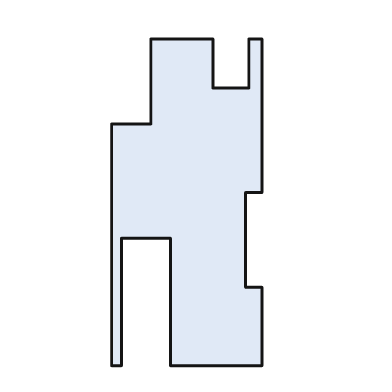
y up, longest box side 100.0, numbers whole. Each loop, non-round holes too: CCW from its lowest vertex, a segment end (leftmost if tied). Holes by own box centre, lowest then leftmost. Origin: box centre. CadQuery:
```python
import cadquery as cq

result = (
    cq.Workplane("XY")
    .moveTo(-23.0, -50.0)
    .lineTo(-20.0, -50.0)
    .lineTo(-20.0, -11.0)
    .lineTo(-5.0, -11.0)
    .lineTo(-5.0, -50.0)
    .lineTo(23.0, -50.0)
    .lineTo(23.0, -26.0)
    .lineTo(18.0, -26.0)
    .lineTo(18.0, 3.0)
    .lineTo(23.0, 3.0)
    .lineTo(23.0, 50.0)
    .lineTo(19.0, 50.0)
    .lineTo(19.0, 35.0)
    .lineTo(8.0, 35.0)
    .lineTo(8.0, 50.0)
    .lineTo(-11.0, 50.0)
    .lineTo(-11.0, 24.0)
    .lineTo(-23.0, 24.0)
    .close()
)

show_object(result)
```